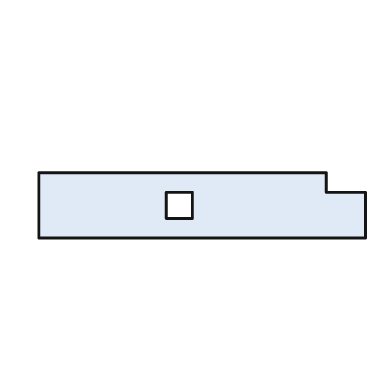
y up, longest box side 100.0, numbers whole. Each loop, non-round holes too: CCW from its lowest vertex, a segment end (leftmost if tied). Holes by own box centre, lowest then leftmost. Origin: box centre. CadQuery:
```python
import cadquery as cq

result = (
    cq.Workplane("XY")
    .moveTo(-50.0, -10.0)
    .lineTo(50.0, -10.0)
    .lineTo(50.0, 4.0)
    .lineTo(38.0, 4.0)
    .lineTo(38.0, 10.0)
    .lineTo(-50.0, 10.0)
    .close()
    .moveTo(-11.0, -4.0)
    .lineTo(-3.0, -4.0)
    .lineTo(-3.0, 4.0)
    .lineTo(-11.0, 4.0)
    .close()
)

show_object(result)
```